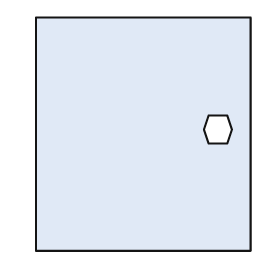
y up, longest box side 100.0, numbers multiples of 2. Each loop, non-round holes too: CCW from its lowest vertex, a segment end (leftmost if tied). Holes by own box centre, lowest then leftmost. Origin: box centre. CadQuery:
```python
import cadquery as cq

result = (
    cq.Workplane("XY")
    .moveTo(-46.0, -50.0)
    .lineTo(46.0, -50.0)
    .lineTo(46.0, 50.0)
    .lineTo(-46.0, 50.0)
    .close()
    .moveTo(28.0, -4.0)
    .lineTo(36.0, -4.0)
    .lineTo(38.0, 2.0)
    .lineTo(36.0, 8.0)
    .lineTo(28.0, 8.0)
    .lineTo(26.0, 2.0)
    .close()
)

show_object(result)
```